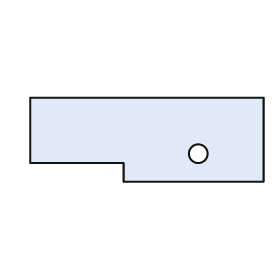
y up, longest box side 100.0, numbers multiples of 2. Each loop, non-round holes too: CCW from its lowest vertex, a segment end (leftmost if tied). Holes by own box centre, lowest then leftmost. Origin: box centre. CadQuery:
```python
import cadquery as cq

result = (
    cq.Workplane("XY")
    .moveTo(-10.0, -18.0)
    .lineTo(50.0, -18.0)
    .lineTo(50.0, 18.0)
    .lineTo(-50.0, 18.0)
    .lineTo(-50.0, -10.0)
    .lineTo(-10.0, -10.0)
    .close()
    .moveTo(22.0, -6.0)
    .circle(4.0)
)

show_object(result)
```